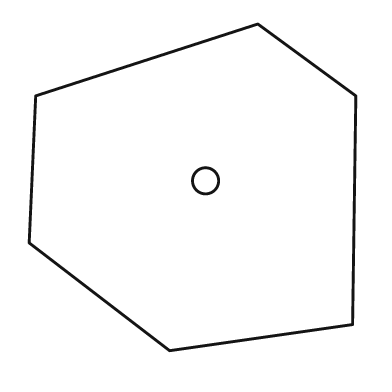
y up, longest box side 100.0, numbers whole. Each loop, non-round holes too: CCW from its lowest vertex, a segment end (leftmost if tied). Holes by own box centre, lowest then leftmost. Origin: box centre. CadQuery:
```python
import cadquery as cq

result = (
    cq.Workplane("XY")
    .moveTo(-7.0, -50.0)
    .lineTo(49.0, -42.0)
    .lineTo(50.0, 28.0)
    .lineTo(20.0, 50.0)
    .lineTo(-48.0, 28.0)
    .lineTo(-50.0, -17.0)
    .close()
    .moveTo(4.0, 2.0)
    .circle(4.0)
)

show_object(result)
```